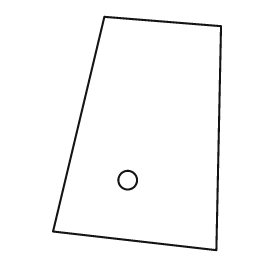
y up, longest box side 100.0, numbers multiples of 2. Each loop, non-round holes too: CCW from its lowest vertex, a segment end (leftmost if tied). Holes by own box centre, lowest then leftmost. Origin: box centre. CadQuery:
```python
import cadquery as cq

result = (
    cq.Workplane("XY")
    .moveTo(34.0, -50.0)
    .lineTo(36.0, 46.0)
    .lineTo(-14.0, 50.0)
    .lineTo(-36.0, -42.0)
    .close()
    .moveTo(-4.0, -20.0)
    .circle(4.0)
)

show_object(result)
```